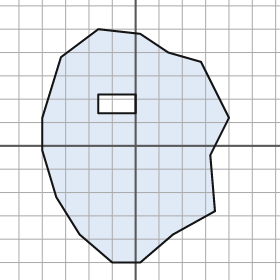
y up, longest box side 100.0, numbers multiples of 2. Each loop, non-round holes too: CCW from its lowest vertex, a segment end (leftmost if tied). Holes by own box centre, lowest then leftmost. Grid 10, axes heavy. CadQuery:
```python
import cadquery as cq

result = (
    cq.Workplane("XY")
    .moveTo(-10.0, -50.0)
    .lineTo(2.0, -50.0)
    .lineTo(16.0, -38.0)
    .lineTo(34.0, -28.0)
    .lineTo(32.0, -4.0)
    .lineTo(40.0, 12.0)
    .lineTo(28.0, 36.0)
    .lineTo(14.0, 40.0)
    .lineTo(2.0, 48.0)
    .lineTo(-16.0, 50.0)
    .lineTo(-32.0, 38.0)
    .lineTo(-40.0, 12.0)
    .lineTo(-40.0, -2.0)
    .lineTo(-34.0, -22.0)
    .lineTo(-24.0, -38.0)
    .close()
    .moveTo(-16.0, 14.0)
    .lineTo(0.0, 14.0)
    .lineTo(0.0, 22.0)
    .lineTo(-16.0, 22.0)
    .close()
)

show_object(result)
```